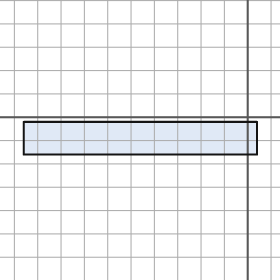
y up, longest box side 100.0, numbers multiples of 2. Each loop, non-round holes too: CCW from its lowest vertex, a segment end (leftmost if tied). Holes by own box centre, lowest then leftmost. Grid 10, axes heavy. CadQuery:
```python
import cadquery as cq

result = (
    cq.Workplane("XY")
    .moveTo(-96.0, -16.0)
    .lineTo(4.0, -16.0)
    .lineTo(4.0, -2.0)
    .lineTo(-96.0, -2.0)
    .close()
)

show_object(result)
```